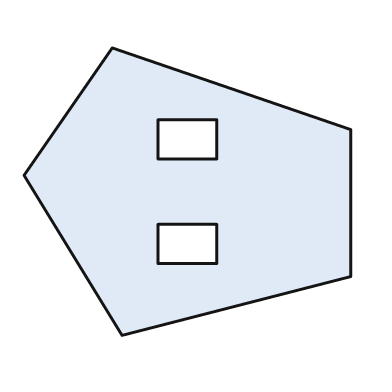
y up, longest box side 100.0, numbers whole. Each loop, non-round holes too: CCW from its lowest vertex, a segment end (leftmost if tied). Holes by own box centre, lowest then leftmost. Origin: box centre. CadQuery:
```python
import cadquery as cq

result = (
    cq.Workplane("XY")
    .moveTo(-20.0, -44.0)
    .lineTo(50.0, -26.0)
    .lineTo(50.0, 19.0)
    .lineTo(-23.0, 44.0)
    .lineTo(-50.0, 5.0)
    .close()
    .moveTo(-9.0, -22.0)
    .lineTo(9.0, -22.0)
    .lineTo(9.0, -10.0)
    .lineTo(-9.0, -10.0)
    .close()
    .moveTo(-9.0, 10.0)
    .lineTo(9.0, 10.0)
    .lineTo(9.0, 22.0)
    .lineTo(-9.0, 22.0)
    .close()
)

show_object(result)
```